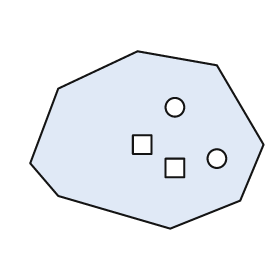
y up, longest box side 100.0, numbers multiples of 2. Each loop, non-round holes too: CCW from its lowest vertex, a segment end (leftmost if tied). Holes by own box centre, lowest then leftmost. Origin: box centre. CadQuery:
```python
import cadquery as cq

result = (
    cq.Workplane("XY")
    .moveTo(10.0, -38.0)
    .lineTo(40.0, -26.0)
    .lineTo(50.0, -2.0)
    .lineTo(30.0, 32.0)
    .lineTo(-4.0, 38.0)
    .lineTo(-38.0, 22.0)
    .lineTo(-50.0, -10.0)
    .lineTo(-38.0, -24.0)
    .close()
    .moveTo(8.0, -16.0)
    .lineTo(16.0, -16.0)
    .lineTo(16.0, -8.0)
    .lineTo(8.0, -8.0)
    .close()
    .moveTo(30.0, -8.0)
    .circle(4.0)
    .moveTo(-6.0, -6.0)
    .lineTo(2.0, -6.0)
    .lineTo(2.0, 2.0)
    .lineTo(-6.0, 2.0)
    .close()
    .moveTo(12.0, 14.0)
    .circle(4.0)
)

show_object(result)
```